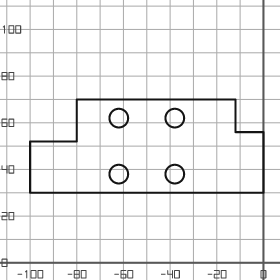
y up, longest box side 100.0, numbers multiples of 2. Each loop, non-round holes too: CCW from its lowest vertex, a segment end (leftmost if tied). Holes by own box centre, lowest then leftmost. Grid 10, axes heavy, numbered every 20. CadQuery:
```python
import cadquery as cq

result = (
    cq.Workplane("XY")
    .moveTo(-100.0, 30.0)
    .lineTo(0.0, 30.0)
    .lineTo(0.0, 56.0)
    .lineTo(-12.0, 56.0)
    .lineTo(-12.0, 70.0)
    .lineTo(-80.0, 70.0)
    .lineTo(-80.0, 52.0)
    .lineTo(-100.0, 52.0)
    .close()
    .moveTo(-62.0, 38.0)
    .circle(4.0)
    .moveTo(-38.0, 38.0)
    .circle(4.0)
    .moveTo(-62.0, 62.0)
    .circle(4.0)
    .moveTo(-38.0, 62.0)
    .circle(4.0)
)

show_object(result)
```